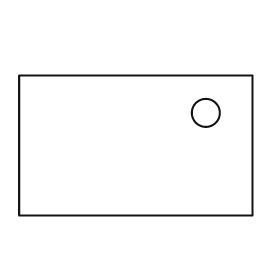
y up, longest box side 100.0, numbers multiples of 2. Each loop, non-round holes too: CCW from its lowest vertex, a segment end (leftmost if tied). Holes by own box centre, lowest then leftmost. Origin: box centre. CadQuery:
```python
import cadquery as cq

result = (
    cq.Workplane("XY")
    .moveTo(-50.0, -30.0)
    .lineTo(50.0, -30.0)
    .lineTo(50.0, 30.0)
    .lineTo(-50.0, 30.0)
    .close()
    .moveTo(30.0, 14.0)
    .circle(6.0)
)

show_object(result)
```